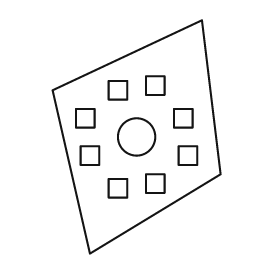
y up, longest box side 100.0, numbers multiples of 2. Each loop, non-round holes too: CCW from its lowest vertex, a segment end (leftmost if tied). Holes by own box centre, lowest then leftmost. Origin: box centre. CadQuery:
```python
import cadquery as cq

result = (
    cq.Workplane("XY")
    .moveTo(-20.0, -50.0)
    .lineTo(36.0, -16.0)
    .lineTo(28.0, 50.0)
    .lineTo(-36.0, 20.0)
    .close()
    .moveTo(-12.0, -26.0)
    .lineTo(-4.0, -26.0)
    .lineTo(-4.0, -18.0)
    .lineTo(-12.0, -18.0)
    .close()
    .moveTo(4.0, -24.0)
    .lineTo(12.0, -24.0)
    .lineTo(12.0, -16.0)
    .lineTo(4.0, -16.0)
    .close()
    .moveTo(-24.0, -12.0)
    .lineTo(-16.0, -12.0)
    .lineTo(-16.0, -4.0)
    .lineTo(-24.0, -4.0)
    .close()
    .moveTo(18.0, -12.0)
    .lineTo(26.0, -12.0)
    .lineTo(26.0, -4.0)
    .lineTo(18.0, -4.0)
    .close()
    .moveTo(0.0, 0.0)
    .circle(8.0)
    .moveTo(-26.0, 4.0)
    .lineTo(-18.0, 4.0)
    .lineTo(-18.0, 12.0)
    .lineTo(-26.0, 12.0)
    .close()
    .moveTo(16.0, 4.0)
    .lineTo(24.0, 4.0)
    .lineTo(24.0, 12.0)
    .lineTo(16.0, 12.0)
    .close()
    .moveTo(-12.0, 16.0)
    .lineTo(-4.0, 16.0)
    .lineTo(-4.0, 24.0)
    .lineTo(-12.0, 24.0)
    .close()
    .moveTo(4.0, 18.0)
    .lineTo(12.0, 18.0)
    .lineTo(12.0, 26.0)
    .lineTo(4.0, 26.0)
    .close()
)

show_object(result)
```